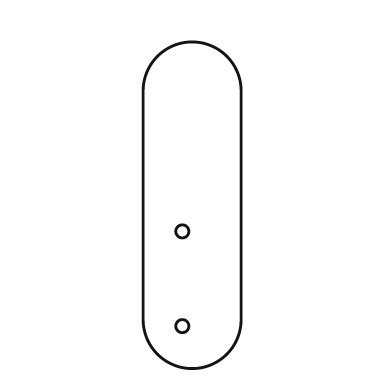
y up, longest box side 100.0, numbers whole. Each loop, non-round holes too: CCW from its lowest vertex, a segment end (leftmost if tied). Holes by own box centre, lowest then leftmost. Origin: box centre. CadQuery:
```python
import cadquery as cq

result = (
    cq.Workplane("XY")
    .moveTo(-15.0, -35.0)
    .threePointArc((0.0, -50.0), (15.0, -35.0))
    .lineTo(15.0, 35.0)
    .threePointArc((0.0, 50.0), (-15.0, 35.0))
    .close()
    .moveTo(-3.0, -37.0)
    .circle(2.0)
    .moveTo(-3.0, -8.0)
    .circle(2.0)
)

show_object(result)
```